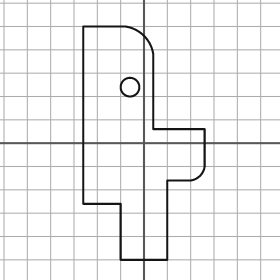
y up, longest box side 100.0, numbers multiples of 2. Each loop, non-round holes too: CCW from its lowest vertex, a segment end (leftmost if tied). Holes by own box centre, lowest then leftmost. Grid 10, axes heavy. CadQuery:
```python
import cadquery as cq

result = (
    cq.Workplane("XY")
    .moveTo(-10.0, -50.0)
    .lineTo(10.0, -50.0)
    .lineTo(10.0, -16.0)
    .lineTo(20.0, -16.0)
    .threePointArc((24.0, -14.0), (26.0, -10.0))
    .lineTo(26.0, 6.0)
    .lineTo(4.0, 6.0)
    .lineTo(4.0, 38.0)
    .threePointArc((0.0, 46.0), (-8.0, 50.0))
    .lineTo(-26.0, 50.0)
    .lineTo(-26.0, -26.0)
    .lineTo(-10.0, -26.0)
    .close()
    .moveTo(-6.0, 24.0)
    .circle(4.0)
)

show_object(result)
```